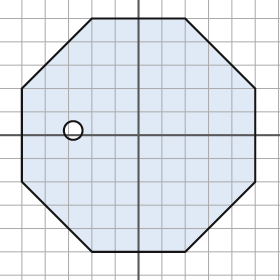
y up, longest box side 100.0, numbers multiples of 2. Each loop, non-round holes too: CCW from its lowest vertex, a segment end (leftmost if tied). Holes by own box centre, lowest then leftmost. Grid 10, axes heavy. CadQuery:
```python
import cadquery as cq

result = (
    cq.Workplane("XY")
    .moveTo(-20.0, -50.0)
    .lineTo(20.0, -50.0)
    .lineTo(50.0, -20.0)
    .lineTo(50.0, 20.0)
    .lineTo(20.0, 50.0)
    .lineTo(-20.0, 50.0)
    .lineTo(-50.0, 20.0)
    .lineTo(-50.0, -20.0)
    .close()
    .moveTo(-28.0, 2.0)
    .circle(4.0)
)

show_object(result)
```